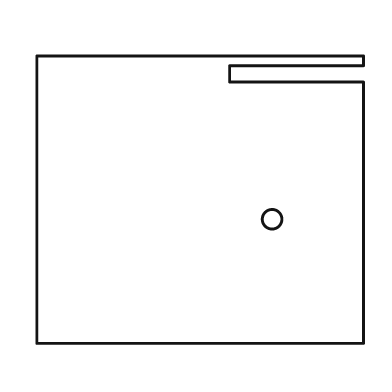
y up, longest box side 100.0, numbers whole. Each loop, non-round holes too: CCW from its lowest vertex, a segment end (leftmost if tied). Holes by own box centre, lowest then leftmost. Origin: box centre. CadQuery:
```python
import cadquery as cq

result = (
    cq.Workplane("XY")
    .moveTo(-50.0, -44.0)
    .lineTo(50.0, -44.0)
    .lineTo(50.0, 36.0)
    .lineTo(9.0, 36.0)
    .lineTo(9.0, 41.0)
    .lineTo(50.0, 41.0)
    .lineTo(50.0, 44.0)
    .lineTo(-50.0, 44.0)
    .close()
    .moveTo(22.0, -6.0)
    .circle(3.0)
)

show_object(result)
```